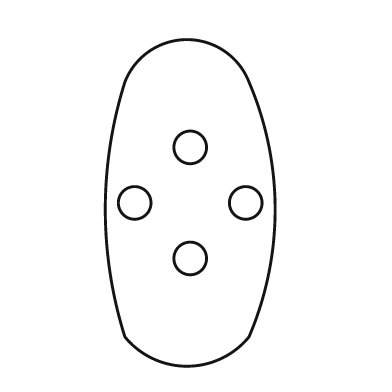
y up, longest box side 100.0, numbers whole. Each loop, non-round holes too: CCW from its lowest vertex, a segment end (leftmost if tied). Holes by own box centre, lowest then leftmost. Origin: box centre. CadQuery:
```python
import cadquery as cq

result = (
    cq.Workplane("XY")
    .moveTo(-20.0, -41.0)
    .threePointArc((-1.0, -50.0), (18.0, -41.0))
    .threePointArc((26.0, -2.0), (18.0, 37.0))
    .threePointArc((-1.0, 50.0), (-20.0, 37.0))
    .threePointArc((-26.0, -2.0), (-20.0, -41.0))
    .close()
    .moveTo(0.0, -17.0)
    .circle(5.0)
    .moveTo(-17.0, 0.0)
    .circle(5.0)
    .moveTo(17.0, 0.0)
    .circle(5.0)
    .moveTo(0.0, 17.0)
    .circle(5.0)
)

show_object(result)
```